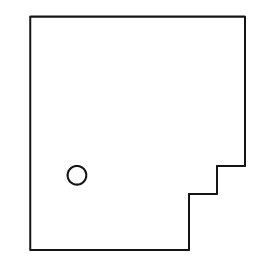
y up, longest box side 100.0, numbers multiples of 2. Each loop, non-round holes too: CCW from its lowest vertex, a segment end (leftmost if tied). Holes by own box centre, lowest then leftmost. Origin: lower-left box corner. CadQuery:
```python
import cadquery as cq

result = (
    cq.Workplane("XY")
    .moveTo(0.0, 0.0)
    .lineTo(68.0, 0.0)
    .lineTo(68.0, 24.0)
    .lineTo(80.0, 24.0)
    .lineTo(80.0, 36.0)
    .lineTo(92.0, 36.0)
    .lineTo(92.0, 100.0)
    .lineTo(0.0, 100.0)
    .close()
    .moveTo(20.0, 32.0)
    .circle(4.0)
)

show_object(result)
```